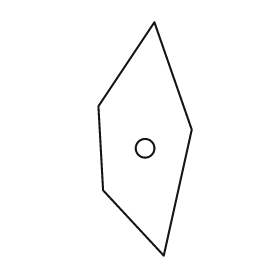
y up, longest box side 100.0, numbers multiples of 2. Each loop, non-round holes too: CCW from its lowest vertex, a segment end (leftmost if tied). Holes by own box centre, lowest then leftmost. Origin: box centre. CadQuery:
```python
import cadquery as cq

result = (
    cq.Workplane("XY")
    .moveTo(8.0, -50.0)
    .lineTo(20.0, 4.0)
    .lineTo(4.0, 50.0)
    .lineTo(-20.0, 14.0)
    .lineTo(-18.0, -22.0)
    .close()
    .moveTo(0.0, -4.0)
    .circle(4.0)
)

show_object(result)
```